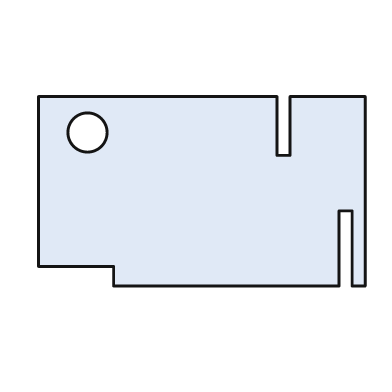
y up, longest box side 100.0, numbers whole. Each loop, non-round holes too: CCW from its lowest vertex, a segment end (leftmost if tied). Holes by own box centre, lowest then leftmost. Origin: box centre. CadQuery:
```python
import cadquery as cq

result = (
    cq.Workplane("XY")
    .moveTo(-27.0, -29.0)
    .lineTo(42.0, -29.0)
    .lineTo(42.0, -6.0)
    .lineTo(46.0, -6.0)
    .lineTo(46.0, -29.0)
    .lineTo(50.0, -29.0)
    .lineTo(50.0, 29.0)
    .lineTo(27.0, 29.0)
    .lineTo(27.0, 11.0)
    .lineTo(23.0, 11.0)
    .lineTo(23.0, 29.0)
    .lineTo(-50.0, 29.0)
    .lineTo(-50.0, -23.0)
    .lineTo(-27.0, -23.0)
    .close()
    .moveTo(-35.0, 18.0)
    .circle(6.0)
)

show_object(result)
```